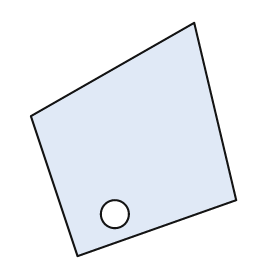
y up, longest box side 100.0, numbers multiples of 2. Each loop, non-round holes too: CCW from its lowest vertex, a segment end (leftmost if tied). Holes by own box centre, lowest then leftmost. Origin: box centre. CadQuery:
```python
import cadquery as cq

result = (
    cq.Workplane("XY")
    .moveTo(-24.0, -50.0)
    .lineTo(44.0, -26.0)
    .lineTo(26.0, 50.0)
    .lineTo(-44.0, 10.0)
    .close()
    .moveTo(-8.0, -32.0)
    .circle(6.0)
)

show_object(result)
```